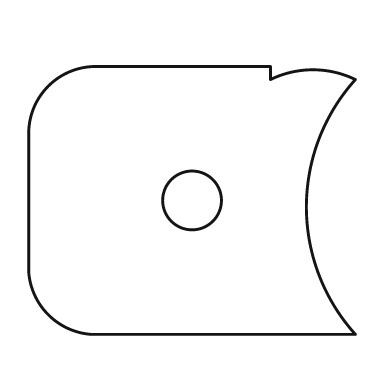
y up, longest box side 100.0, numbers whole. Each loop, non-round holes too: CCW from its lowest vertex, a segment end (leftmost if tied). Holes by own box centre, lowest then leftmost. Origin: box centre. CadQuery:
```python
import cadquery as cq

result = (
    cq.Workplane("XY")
    .moveTo(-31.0, -41.0)
    .lineTo(50.0, -41.0)
    .threePointArc((35.0, -2.0), (50.0, 37.0))
    .threePointArc((37.0, 40.0), (24.0, 37.0))
    .lineTo(24.0, 41.0)
    .lineTo(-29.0, 41.0)
    .threePointArc((-44.0, 35.0), (-50.0, 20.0))
    .lineTo(-50.0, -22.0)
    .threePointArc((-44.0, -35.0), (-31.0, -41.0))
    .close()
    .moveTo(0.0, 0.0)
    .circle(9.0)
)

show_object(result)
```